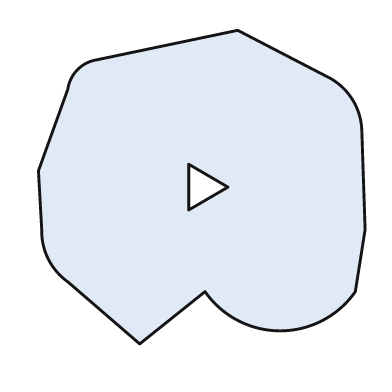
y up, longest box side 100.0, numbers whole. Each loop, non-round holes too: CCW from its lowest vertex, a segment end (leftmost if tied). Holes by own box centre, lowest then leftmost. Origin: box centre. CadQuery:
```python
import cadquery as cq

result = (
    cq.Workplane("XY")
    .moveTo(-19.0, -48.0)
    .lineTo(1.0, -32.0)
    .threePointArc((24.0, -44.0), (47.0, -32.0))
    .lineTo(50.0, -13.0)
    .lineTo(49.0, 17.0)
    .threePointArc((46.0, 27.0), (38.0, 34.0))
    .lineTo(11.0, 48.0)
    .lineTo(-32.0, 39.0)
    .threePointArc((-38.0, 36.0), (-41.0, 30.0))
    .lineTo(-50.0, 5.0)
    .lineTo(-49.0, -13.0)
    .threePointArc((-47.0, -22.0), (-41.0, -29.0))
    .close()
    .moveTo(-4.0, -7.0)
    .lineTo(8.0, 0.0)
    .lineTo(-4.0, 7.0)
    .close()
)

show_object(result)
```